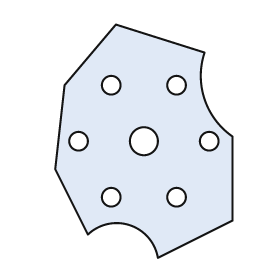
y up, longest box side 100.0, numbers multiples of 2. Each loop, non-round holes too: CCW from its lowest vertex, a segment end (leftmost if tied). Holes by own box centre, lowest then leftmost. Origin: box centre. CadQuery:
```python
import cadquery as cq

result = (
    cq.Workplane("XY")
    .moveTo(6.0, -50.0)
    .lineTo(38.0, -34.0)
    .lineTo(38.0, 2.0)
    .threePointArc((26.0, 18.0), (26.0, 38.0))
    .lineTo(-12.0, 50.0)
    .lineTo(-34.0, 24.0)
    .lineTo(-38.0, -12.0)
    .lineTo(-24.0, -40.0)
    .threePointArc((-6.0, -36.0), (6.0, -50.0))
    .close()
    .moveTo(-14.0, -24.0)
    .circle(4.0)
    .moveTo(14.0, -24.0)
    .circle(4.0)
    .moveTo(-28.0, 0.0)
    .circle(4.0)
    .moveTo(0.0, 0.0)
    .circle(6.0)
    .moveTo(28.0, 0.0)
    .circle(4.0)
    .moveTo(-14.0, 24.0)
    .circle(4.0)
    .moveTo(14.0, 24.0)
    .circle(4.0)
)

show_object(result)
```